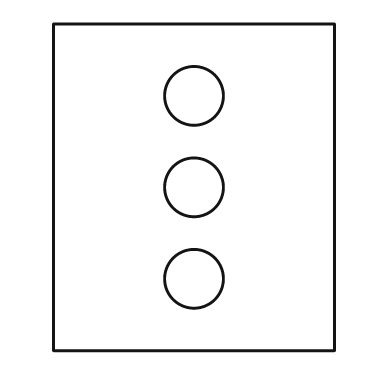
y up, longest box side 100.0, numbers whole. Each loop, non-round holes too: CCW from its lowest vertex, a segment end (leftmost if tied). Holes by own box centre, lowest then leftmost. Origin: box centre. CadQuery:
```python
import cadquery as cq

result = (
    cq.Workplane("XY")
    .moveTo(-43.0, -50.0)
    .lineTo(43.0, -50.0)
    .lineTo(43.0, 50.0)
    .lineTo(-43.0, 50.0)
    .close()
    .moveTo(0.0, -28.0)
    .circle(9.0)
    .moveTo(0.0, 0.0)
    .circle(9.0)
    .moveTo(0.0, 28.0)
    .circle(9.0)
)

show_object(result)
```